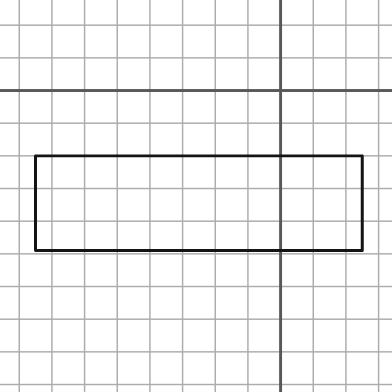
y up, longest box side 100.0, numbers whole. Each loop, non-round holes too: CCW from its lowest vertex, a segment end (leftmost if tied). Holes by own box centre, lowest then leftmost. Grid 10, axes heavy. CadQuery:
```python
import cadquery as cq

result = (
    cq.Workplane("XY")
    .moveTo(-75.0, -49.0)
    .lineTo(25.0, -49.0)
    .lineTo(25.0, -20.0)
    .lineTo(-75.0, -20.0)
    .close()
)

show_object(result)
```